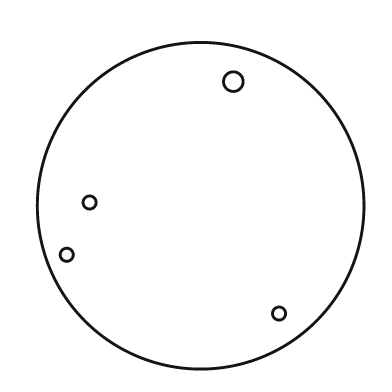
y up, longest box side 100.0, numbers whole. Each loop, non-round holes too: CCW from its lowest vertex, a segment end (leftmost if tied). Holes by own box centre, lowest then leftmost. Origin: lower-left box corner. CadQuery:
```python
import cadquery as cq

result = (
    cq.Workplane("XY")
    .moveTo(50.0, 50.0)
    .circle(50.0)
    .moveTo(74.0, 17.0)
    .circle(2.0)
    .moveTo(9.0, 35.0)
    .circle(2.0)
    .moveTo(16.0, 51.0)
    .circle(2.0)
    .moveTo(60.0, 88.0)
    .circle(3.0)
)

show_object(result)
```